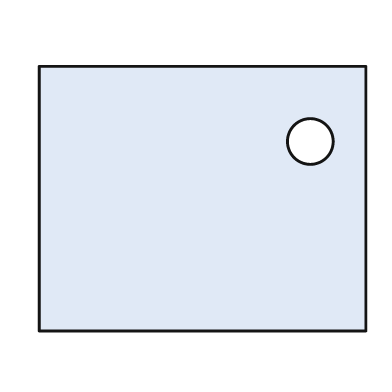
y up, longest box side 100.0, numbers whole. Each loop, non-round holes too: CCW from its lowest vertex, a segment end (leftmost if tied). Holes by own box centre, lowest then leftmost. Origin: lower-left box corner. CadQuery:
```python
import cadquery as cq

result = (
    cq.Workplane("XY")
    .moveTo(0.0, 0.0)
    .lineTo(100.0, 0.0)
    .lineTo(100.0, 81.0)
    .lineTo(0.0, 81.0)
    .close()
    .moveTo(83.0, 58.0)
    .circle(7.0)
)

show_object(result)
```